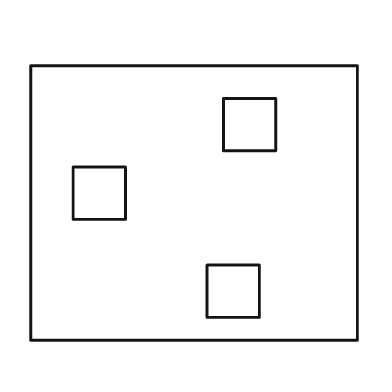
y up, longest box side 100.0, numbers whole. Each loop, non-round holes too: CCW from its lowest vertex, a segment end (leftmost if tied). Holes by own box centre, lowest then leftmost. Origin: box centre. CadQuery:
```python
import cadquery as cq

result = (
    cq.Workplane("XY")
    .moveTo(-50.0, -42.0)
    .lineTo(50.0, -42.0)
    .lineTo(50.0, 42.0)
    .lineTo(-50.0, 42.0)
    .close()
    .moveTo(4.0, -35.0)
    .lineTo(20.0, -35.0)
    .lineTo(20.0, -19.0)
    .lineTo(4.0, -19.0)
    .close()
    .moveTo(-37.0, -5.0)
    .lineTo(-21.0, -5.0)
    .lineTo(-21.0, 11.0)
    .lineTo(-37.0, 11.0)
    .close()
    .moveTo(9.0, 16.0)
    .lineTo(25.0, 16.0)
    .lineTo(25.0, 32.0)
    .lineTo(9.0, 32.0)
    .close()
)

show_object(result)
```